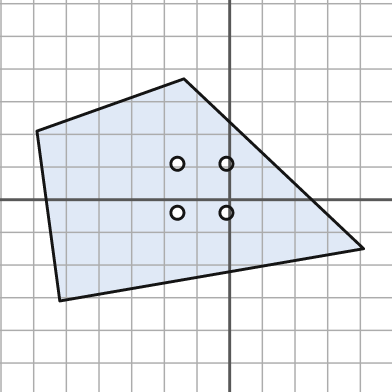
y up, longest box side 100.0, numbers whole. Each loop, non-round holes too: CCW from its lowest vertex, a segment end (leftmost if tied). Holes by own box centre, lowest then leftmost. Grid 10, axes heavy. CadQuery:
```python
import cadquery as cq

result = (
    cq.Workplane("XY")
    .moveTo(-52.0, -31.0)
    .lineTo(41.0, -15.0)
    .lineTo(-14.0, 37.0)
    .lineTo(-59.0, 21.0)
    .close()
    .moveTo(-16.0, -4.0)
    .circle(2.0)
    .moveTo(-1.0, -4.0)
    .circle(2.0)
    .moveTo(-16.0, 11.0)
    .circle(2.0)
    .moveTo(-1.0, 11.0)
    .circle(2.0)
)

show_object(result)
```